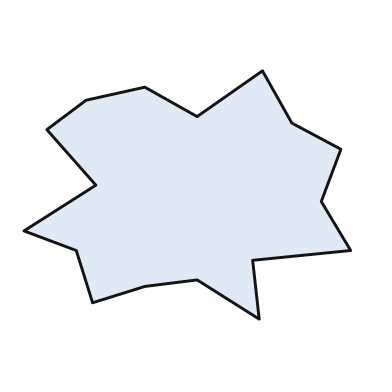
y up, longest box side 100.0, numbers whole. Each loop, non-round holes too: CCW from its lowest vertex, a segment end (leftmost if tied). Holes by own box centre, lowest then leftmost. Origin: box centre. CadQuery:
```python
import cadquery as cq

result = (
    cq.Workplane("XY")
    .moveTo(22.0, -38.0)
    .lineTo(20.0, -20.0)
    .lineTo(50.0, -17.0)
    .lineTo(41.0, -2.0)
    .lineTo(47.0, 14.0)
    .lineTo(32.0, 22.0)
    .lineTo(23.0, 38.0)
    .lineTo(3.0, 24.0)
    .lineTo(-13.0, 33.0)
    .lineTo(-31.0, 29.0)
    .lineTo(-43.0, 20.0)
    .lineTo(-28.0, 3.0)
    .lineTo(-50.0, -11.0)
    .lineTo(-34.0, -17.0)
    .lineTo(-29.0, -33.0)
    .lineTo(-13.0, -28.0)
    .lineTo(3.0, -26.0)
    .close()
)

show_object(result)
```